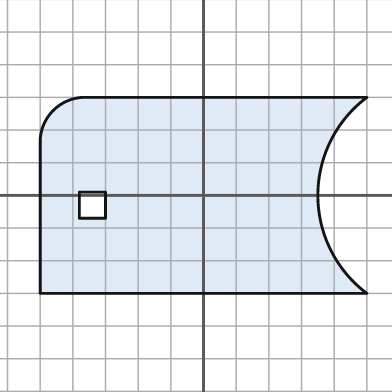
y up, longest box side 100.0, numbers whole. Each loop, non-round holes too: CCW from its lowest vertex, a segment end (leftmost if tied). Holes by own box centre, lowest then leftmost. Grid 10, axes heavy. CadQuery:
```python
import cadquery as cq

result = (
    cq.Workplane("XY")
    .moveTo(-50.0, -30.0)
    .lineTo(50.0, -30.0)
    .threePointArc((35.0, 0.0), (50.0, 30.0))
    .lineTo(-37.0, 30.0)
    .threePointArc((-46.0, 26.0), (-50.0, 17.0))
    .close()
    .moveTo(-38.0, -7.0)
    .lineTo(-30.0, -7.0)
    .lineTo(-30.0, 1.0)
    .lineTo(-38.0, 1.0)
    .close()
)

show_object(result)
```